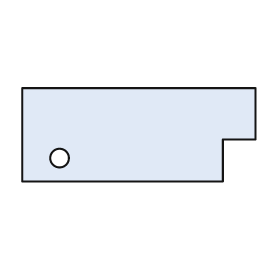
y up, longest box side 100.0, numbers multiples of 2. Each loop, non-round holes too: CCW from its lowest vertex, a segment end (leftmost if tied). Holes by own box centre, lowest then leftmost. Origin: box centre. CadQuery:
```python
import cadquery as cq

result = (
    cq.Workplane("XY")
    .moveTo(-50.0, -20.0)
    .lineTo(36.0, -20.0)
    .lineTo(36.0, -2.0)
    .lineTo(50.0, -2.0)
    .lineTo(50.0, 20.0)
    .lineTo(-50.0, 20.0)
    .close()
    .moveTo(-34.0, -10.0)
    .circle(4.0)
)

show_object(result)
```